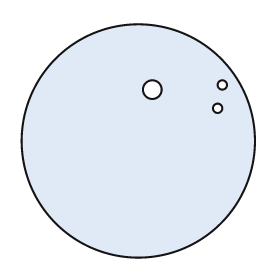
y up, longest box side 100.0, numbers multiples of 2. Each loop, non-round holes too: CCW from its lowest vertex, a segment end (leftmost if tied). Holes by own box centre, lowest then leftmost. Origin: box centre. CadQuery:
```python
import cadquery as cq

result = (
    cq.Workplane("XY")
    .moveTo(0.0, 0.0)
    .circle(50.0)
    .moveTo(34.0, 14.0)
    .circle(2.0)
    .moveTo(6.0, 22.0)
    .circle(4.0)
    .moveTo(36.0, 24.0)
    .circle(2.0)
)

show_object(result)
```